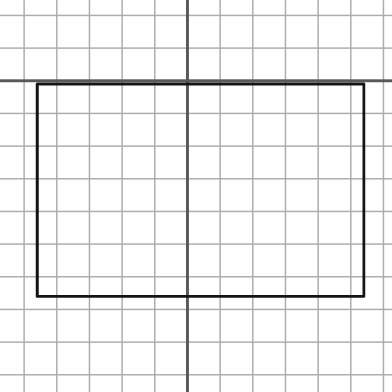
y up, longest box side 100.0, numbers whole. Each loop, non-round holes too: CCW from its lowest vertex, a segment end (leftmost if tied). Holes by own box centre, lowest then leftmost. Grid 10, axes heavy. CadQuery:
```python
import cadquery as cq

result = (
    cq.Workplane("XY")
    .moveTo(-46.0, -66.0)
    .lineTo(54.0, -66.0)
    .lineTo(54.0, -1.0)
    .lineTo(-46.0, -1.0)
    .close()
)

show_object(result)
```